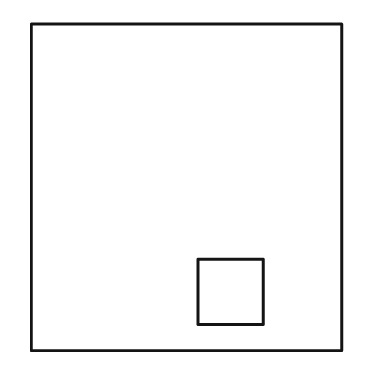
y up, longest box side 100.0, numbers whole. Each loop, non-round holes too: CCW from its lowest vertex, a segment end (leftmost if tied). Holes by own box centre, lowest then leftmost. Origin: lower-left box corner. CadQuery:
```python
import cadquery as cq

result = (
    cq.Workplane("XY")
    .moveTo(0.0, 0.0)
    .lineTo(95.0, 0.0)
    .lineTo(95.0, 100.0)
    .lineTo(0.0, 100.0)
    .close()
    .moveTo(51.0, 8.0)
    .lineTo(71.0, 8.0)
    .lineTo(71.0, 28.0)
    .lineTo(51.0, 28.0)
    .close()
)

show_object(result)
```